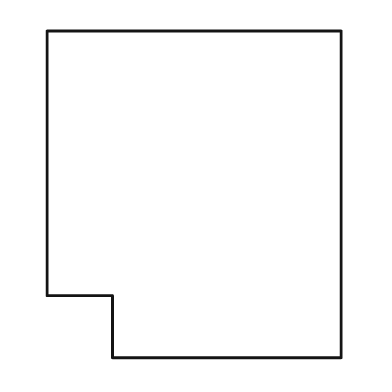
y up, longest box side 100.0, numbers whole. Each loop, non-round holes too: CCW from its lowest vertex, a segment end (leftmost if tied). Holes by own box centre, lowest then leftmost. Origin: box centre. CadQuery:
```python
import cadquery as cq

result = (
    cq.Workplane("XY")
    .moveTo(-25.0, -50.0)
    .lineTo(45.0, -50.0)
    .lineTo(45.0, 50.0)
    .lineTo(-45.0, 50.0)
    .lineTo(-45.0, -31.0)
    .lineTo(-25.0, -31.0)
    .close()
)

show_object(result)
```